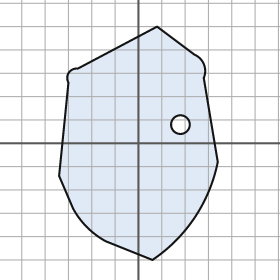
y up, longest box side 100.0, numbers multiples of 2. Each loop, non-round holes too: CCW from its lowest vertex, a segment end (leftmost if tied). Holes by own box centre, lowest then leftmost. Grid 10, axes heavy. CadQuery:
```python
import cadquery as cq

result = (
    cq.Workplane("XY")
    .moveTo(6.0, -50.0)
    .threePointArc((24.0, -32.0), (34.0, -8.0))
    .lineTo(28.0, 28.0)
    .threePointArc((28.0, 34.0), (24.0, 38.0))
    .lineTo(8.0, 50.0)
    .lineTo(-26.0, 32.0)
    .threePointArc((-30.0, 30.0), (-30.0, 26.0))
    .lineTo(-34.0, -14.0)
    .lineTo(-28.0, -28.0)
    .threePointArc((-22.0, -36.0), (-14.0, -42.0))
    .close()
    .moveTo(18.0, 8.0)
    .circle(4.0)
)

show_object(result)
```